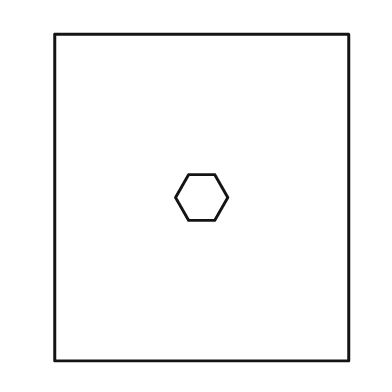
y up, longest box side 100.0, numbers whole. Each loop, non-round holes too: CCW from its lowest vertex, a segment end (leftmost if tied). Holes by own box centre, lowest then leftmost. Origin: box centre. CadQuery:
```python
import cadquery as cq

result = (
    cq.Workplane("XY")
    .moveTo(-45.0, -50.0)
    .lineTo(45.0, -50.0)
    .lineTo(45.0, 50.0)
    .lineTo(-45.0, 50.0)
    .close()
    .moveTo(-4.0, -7.0)
    .lineTo(4.0, -7.0)
    .lineTo(8.0, 0.0)
    .lineTo(4.0, 7.0)
    .lineTo(-4.0, 7.0)
    .lineTo(-8.0, 0.0)
    .close()
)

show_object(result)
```